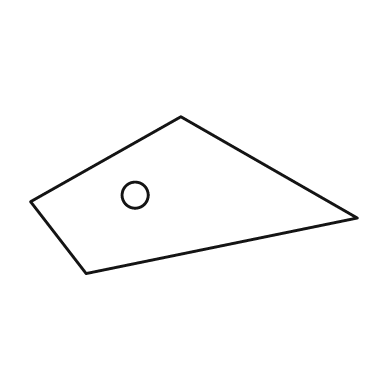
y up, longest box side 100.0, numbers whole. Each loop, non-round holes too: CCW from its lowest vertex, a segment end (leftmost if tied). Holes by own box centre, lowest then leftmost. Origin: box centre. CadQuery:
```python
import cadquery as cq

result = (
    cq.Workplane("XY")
    .moveTo(-33.0, -24.0)
    .lineTo(50.0, -7.0)
    .lineTo(-4.0, 24.0)
    .lineTo(-50.0, -2.0)
    .close()
    .moveTo(-18.0, 0.0)
    .circle(4.0)
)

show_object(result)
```